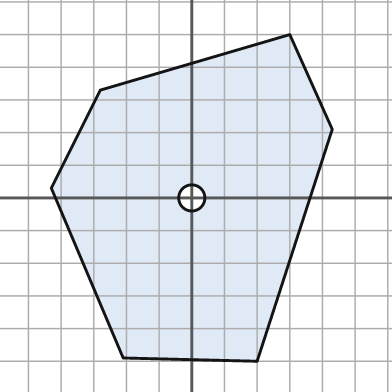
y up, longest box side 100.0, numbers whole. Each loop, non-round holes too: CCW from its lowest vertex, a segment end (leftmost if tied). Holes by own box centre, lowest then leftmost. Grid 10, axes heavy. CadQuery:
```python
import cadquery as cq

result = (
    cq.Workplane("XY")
    .moveTo(20.0, -50.0)
    .lineTo(43.0, 21.0)
    .lineTo(30.0, 50.0)
    .lineTo(-28.0, 33.0)
    .lineTo(-43.0, 3.0)
    .lineTo(-21.0, -49.0)
    .close()
    .moveTo(0.0, 0.0)
    .circle(4.0)
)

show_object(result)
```